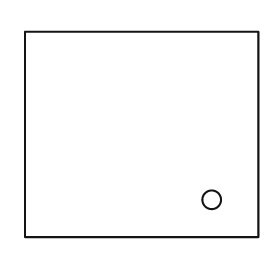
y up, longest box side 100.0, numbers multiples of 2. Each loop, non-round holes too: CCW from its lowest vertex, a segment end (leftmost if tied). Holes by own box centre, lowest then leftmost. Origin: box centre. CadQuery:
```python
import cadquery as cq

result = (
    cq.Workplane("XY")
    .moveTo(-50.0, -44.0)
    .lineTo(50.0, -44.0)
    .lineTo(50.0, 44.0)
    .lineTo(-50.0, 44.0)
    .close()
    .moveTo(30.0, -28.0)
    .circle(4.0)
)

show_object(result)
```